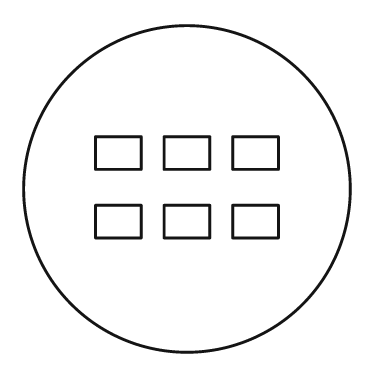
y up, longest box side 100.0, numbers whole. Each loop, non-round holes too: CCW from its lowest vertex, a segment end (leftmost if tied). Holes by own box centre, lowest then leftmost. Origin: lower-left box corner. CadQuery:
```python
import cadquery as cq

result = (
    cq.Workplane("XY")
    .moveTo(50.0, 50.0)
    .circle(50.0)
    .moveTo(22.0, 35.0)
    .lineTo(36.0, 35.0)
    .lineTo(36.0, 45.0)
    .lineTo(22.0, 45.0)
    .close()
    .moveTo(43.0, 35.0)
    .lineTo(57.0, 35.0)
    .lineTo(57.0, 45.0)
    .lineTo(43.0, 45.0)
    .close()
    .moveTo(64.0, 35.0)
    .lineTo(78.0, 35.0)
    .lineTo(78.0, 45.0)
    .lineTo(64.0, 45.0)
    .close()
    .moveTo(22.0, 56.0)
    .lineTo(36.0, 56.0)
    .lineTo(36.0, 66.0)
    .lineTo(22.0, 66.0)
    .close()
    .moveTo(43.0, 56.0)
    .lineTo(57.0, 56.0)
    .lineTo(57.0, 66.0)
    .lineTo(43.0, 66.0)
    .close()
    .moveTo(64.0, 56.0)
    .lineTo(78.0, 56.0)
    .lineTo(78.0, 66.0)
    .lineTo(64.0, 66.0)
    .close()
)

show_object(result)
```